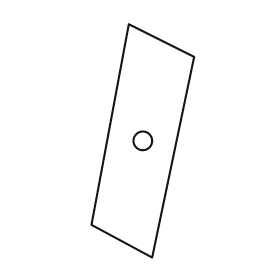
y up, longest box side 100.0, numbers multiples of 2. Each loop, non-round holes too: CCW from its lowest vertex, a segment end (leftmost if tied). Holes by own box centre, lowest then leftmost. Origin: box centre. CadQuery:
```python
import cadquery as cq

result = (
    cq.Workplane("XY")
    .moveTo(4.0, -50.0)
    .lineTo(22.0, 36.0)
    .lineTo(-6.0, 50.0)
    .lineTo(-22.0, -36.0)
    .close()
    .moveTo(0.0, 0.0)
    .circle(4.0)
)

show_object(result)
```